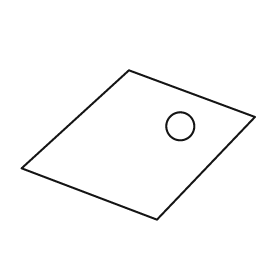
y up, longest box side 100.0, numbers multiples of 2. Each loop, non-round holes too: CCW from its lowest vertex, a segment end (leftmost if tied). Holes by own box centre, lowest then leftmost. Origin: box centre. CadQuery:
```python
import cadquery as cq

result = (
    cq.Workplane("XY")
    .moveTo(8.0, -32.0)
    .lineTo(50.0, 12.0)
    .lineTo(-4.0, 32.0)
    .lineTo(-50.0, -10.0)
    .close()
    .moveTo(18.0, 8.0)
    .circle(6.0)
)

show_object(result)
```